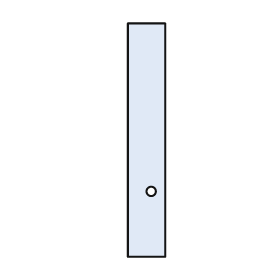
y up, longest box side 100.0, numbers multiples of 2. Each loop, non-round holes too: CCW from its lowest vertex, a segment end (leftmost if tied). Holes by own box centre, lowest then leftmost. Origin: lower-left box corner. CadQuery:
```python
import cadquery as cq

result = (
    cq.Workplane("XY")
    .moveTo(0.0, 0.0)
    .lineTo(16.0, 0.0)
    .lineTo(16.0, 100.0)
    .lineTo(0.0, 100.0)
    .close()
    .moveTo(10.0, 28.0)
    .circle(2.0)
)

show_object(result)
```